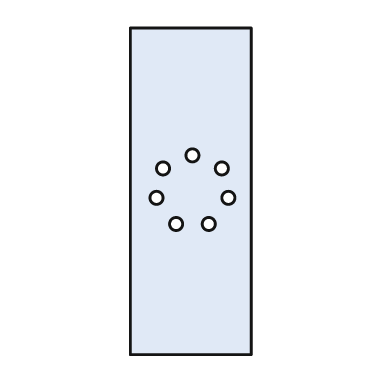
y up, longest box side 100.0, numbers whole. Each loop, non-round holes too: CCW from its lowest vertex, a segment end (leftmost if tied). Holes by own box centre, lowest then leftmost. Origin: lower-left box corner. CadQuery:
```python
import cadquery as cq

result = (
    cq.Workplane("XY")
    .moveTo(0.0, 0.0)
    .lineTo(37.0, 0.0)
    .lineTo(37.0, 100.0)
    .lineTo(0.0, 100.0)
    .close()
    .moveTo(14.0, 40.0)
    .circle(2.0)
    .moveTo(24.0, 40.0)
    .circle(2.0)
    .moveTo(8.0, 48.0)
    .circle(2.0)
    .moveTo(30.0, 48.0)
    .circle(2.0)
    .moveTo(10.0, 57.0)
    .circle(2.0)
    .moveTo(28.0, 57.0)
    .circle(2.0)
    .moveTo(19.0, 61.0)
    .circle(2.0)
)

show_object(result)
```